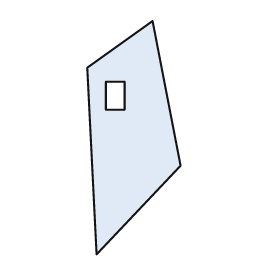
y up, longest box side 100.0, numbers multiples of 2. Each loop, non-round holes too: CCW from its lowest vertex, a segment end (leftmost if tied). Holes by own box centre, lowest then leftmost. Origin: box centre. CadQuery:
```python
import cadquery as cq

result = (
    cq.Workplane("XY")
    .moveTo(-16.0, -50.0)
    .lineTo(20.0, -12.0)
    .lineTo(8.0, 50.0)
    .lineTo(-20.0, 30.0)
    .close()
    .moveTo(-12.0, 12.0)
    .lineTo(-4.0, 12.0)
    .lineTo(-4.0, 24.0)
    .lineTo(-12.0, 24.0)
    .close()
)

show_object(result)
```